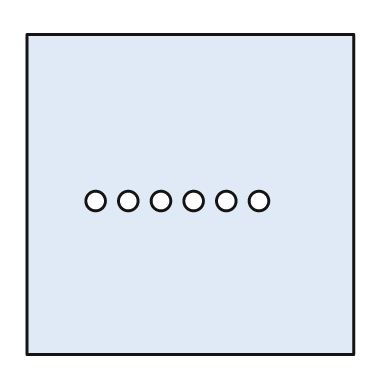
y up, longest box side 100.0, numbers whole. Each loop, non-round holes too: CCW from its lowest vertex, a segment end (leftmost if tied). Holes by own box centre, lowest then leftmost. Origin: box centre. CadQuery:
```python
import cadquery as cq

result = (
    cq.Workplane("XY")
    .moveTo(-50.0, -49.0)
    .lineTo(50.0, -49.0)
    .lineTo(50.0, 49.0)
    .lineTo(-50.0, 49.0)
    .close()
    .moveTo(-29.0, -2.0)
    .circle(3.0)
    .moveTo(-19.0, -2.0)
    .circle(3.0)
    .moveTo(-9.0, -2.0)
    .circle(3.0)
    .moveTo(1.0, -2.0)
    .circle(3.0)
    .moveTo(11.0, -2.0)
    .circle(3.0)
    .moveTo(21.0, -2.0)
    .circle(3.0)
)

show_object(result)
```